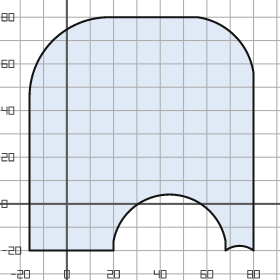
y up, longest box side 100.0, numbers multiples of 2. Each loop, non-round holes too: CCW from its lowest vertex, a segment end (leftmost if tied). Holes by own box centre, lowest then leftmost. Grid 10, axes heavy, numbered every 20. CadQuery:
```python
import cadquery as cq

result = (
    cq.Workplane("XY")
    .moveTo(-16.0, -20.0)
    .lineTo(20.0, -20.0)
    .lineTo(20.0, -16.0)
    .threePointArc((44.0, 4.0), (68.0, -16.0))
    .lineTo(68.0, -20.0)
    .threePointArc((74.0, -18.0), (80.0, -20.0))
    .lineTo(80.0, 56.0)
    .threePointArc((72.0, 72.0), (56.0, 80.0))
    .lineTo(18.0, 80.0)
    .threePointArc((-6.0, 70.0), (-16.0, 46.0))
    .close()
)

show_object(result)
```